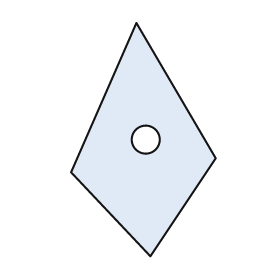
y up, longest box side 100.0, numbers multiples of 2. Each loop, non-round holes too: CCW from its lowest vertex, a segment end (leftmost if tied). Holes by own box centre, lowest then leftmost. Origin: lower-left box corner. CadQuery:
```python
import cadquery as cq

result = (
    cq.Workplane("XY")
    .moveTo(34.0, 0.0)
    .lineTo(62.0, 42.0)
    .lineTo(28.0, 100.0)
    .lineTo(0.0, 36.0)
    .close()
    .moveTo(32.0, 50.0)
    .circle(6.0)
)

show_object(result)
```